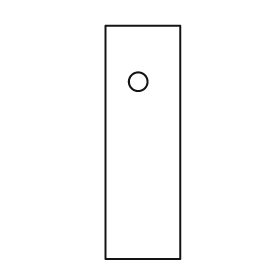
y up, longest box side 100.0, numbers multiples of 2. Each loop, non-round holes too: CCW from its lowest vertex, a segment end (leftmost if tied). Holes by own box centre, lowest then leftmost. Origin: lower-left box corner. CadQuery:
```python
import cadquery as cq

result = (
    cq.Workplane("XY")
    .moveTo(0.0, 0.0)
    .lineTo(32.0, 0.0)
    .lineTo(32.0, 100.0)
    .lineTo(0.0, 100.0)
    .close()
    .moveTo(14.0, 76.0)
    .circle(4.0)
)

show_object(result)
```